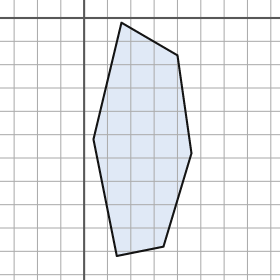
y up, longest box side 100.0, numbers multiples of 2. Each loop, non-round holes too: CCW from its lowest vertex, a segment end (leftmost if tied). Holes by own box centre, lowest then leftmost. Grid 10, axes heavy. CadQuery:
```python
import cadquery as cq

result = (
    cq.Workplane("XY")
    .moveTo(14.0, -102.0)
    .lineTo(34.0, -98.0)
    .lineTo(46.0, -58.0)
    .lineTo(40.0, -16.0)
    .lineTo(16.0, -2.0)
    .lineTo(4.0, -52.0)
    .close()
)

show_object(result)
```